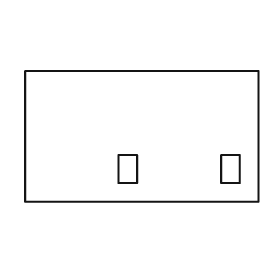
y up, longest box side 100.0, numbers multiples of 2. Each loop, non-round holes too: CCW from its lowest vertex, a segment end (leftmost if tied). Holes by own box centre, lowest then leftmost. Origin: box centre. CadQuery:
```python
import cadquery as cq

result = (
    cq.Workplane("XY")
    .moveTo(-50.0, -28.0)
    .lineTo(50.0, -28.0)
    .lineTo(50.0, 28.0)
    .lineTo(-50.0, 28.0)
    .close()
    .moveTo(-10.0, -20.0)
    .lineTo(-2.0, -20.0)
    .lineTo(-2.0, -8.0)
    .lineTo(-10.0, -8.0)
    .close()
    .moveTo(34.0, -20.0)
    .lineTo(42.0, -20.0)
    .lineTo(42.0, -8.0)
    .lineTo(34.0, -8.0)
    .close()
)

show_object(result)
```